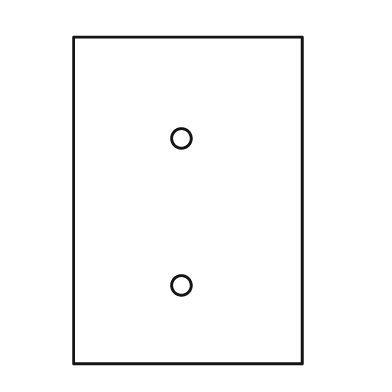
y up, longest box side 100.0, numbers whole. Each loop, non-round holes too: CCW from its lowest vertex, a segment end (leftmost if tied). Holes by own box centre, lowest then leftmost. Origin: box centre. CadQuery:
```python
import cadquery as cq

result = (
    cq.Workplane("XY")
    .moveTo(-35.0, -50.0)
    .lineTo(35.0, -50.0)
    .lineTo(35.0, 50.0)
    .lineTo(-35.0, 50.0)
    .close()
    .moveTo(-2.0, -26.0)
    .circle(3.0)
    .moveTo(-2.0, 19.0)
    .circle(3.0)
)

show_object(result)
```